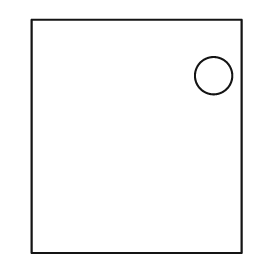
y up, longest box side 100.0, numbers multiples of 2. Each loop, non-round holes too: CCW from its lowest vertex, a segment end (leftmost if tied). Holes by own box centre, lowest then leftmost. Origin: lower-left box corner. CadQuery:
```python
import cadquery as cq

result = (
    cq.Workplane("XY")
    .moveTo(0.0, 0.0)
    .lineTo(90.0, 0.0)
    .lineTo(90.0, 100.0)
    .lineTo(0.0, 100.0)
    .close()
    .moveTo(78.0, 76.0)
    .circle(8.0)
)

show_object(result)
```